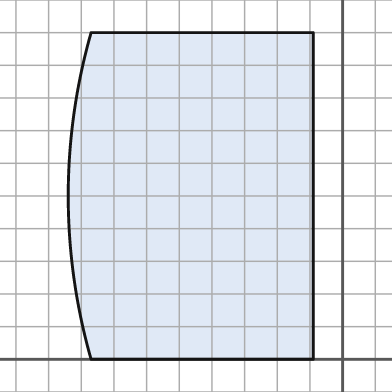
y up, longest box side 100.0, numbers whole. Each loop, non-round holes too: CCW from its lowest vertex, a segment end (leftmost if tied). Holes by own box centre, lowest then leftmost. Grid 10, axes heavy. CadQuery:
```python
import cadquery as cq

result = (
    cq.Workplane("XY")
    .moveTo(-77.0, 0.0)
    .lineTo(-9.0, 0.0)
    .lineTo(-9.0, 100.0)
    .lineTo(-77.0, 100.0)
    .threePointArc((-84.0, 50.0), (-77.0, 0.0))
    .close()
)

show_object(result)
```